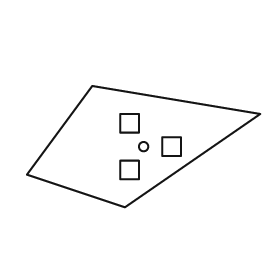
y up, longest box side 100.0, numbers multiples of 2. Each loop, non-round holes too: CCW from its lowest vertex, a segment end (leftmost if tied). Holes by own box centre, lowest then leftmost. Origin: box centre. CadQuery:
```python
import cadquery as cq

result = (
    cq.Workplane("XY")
    .moveTo(-8.0, -26.0)
    .lineTo(50.0, 14.0)
    .lineTo(-22.0, 26.0)
    .lineTo(-50.0, -12.0)
    .close()
    .moveTo(-10.0, -14.0)
    .lineTo(-2.0, -14.0)
    .lineTo(-2.0, -6.0)
    .lineTo(-10.0, -6.0)
    .close()
    .moveTo(0.0, 0.0)
    .circle(2.0)
    .moveTo(8.0, -4.0)
    .lineTo(16.0, -4.0)
    .lineTo(16.0, 4.0)
    .lineTo(8.0, 4.0)
    .close()
    .moveTo(-10.0, 6.0)
    .lineTo(-2.0, 6.0)
    .lineTo(-2.0, 14.0)
    .lineTo(-10.0, 14.0)
    .close()
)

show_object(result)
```